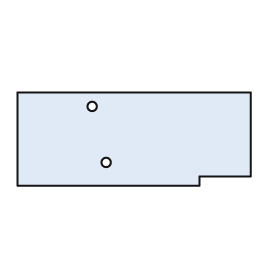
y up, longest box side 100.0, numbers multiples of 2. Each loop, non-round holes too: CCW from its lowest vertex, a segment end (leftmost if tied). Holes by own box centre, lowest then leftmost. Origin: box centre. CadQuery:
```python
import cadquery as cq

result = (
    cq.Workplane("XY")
    .moveTo(-50.0, -20.0)
    .lineTo(28.0, -20.0)
    .lineTo(28.0, -16.0)
    .lineTo(50.0, -16.0)
    .lineTo(50.0, 20.0)
    .lineTo(-50.0, 20.0)
    .close()
    .moveTo(-12.0, -10.0)
    .circle(2.0)
    .moveTo(-18.0, 14.0)
    .circle(2.0)
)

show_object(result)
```